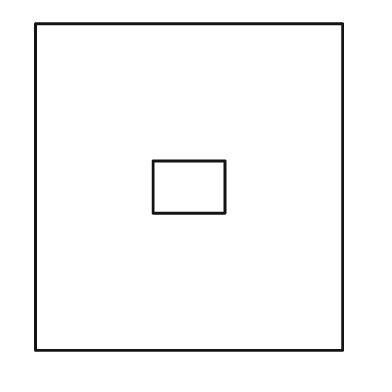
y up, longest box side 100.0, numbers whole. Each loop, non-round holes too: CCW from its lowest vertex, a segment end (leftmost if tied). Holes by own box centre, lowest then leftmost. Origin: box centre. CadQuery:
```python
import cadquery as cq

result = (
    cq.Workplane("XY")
    .moveTo(-47.0, -50.0)
    .lineTo(47.0, -50.0)
    .lineTo(47.0, 50.0)
    .lineTo(-47.0, 50.0)
    .close()
    .moveTo(-11.0, -8.0)
    .lineTo(11.0, -8.0)
    .lineTo(11.0, 8.0)
    .lineTo(-11.0, 8.0)
    .close()
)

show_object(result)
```